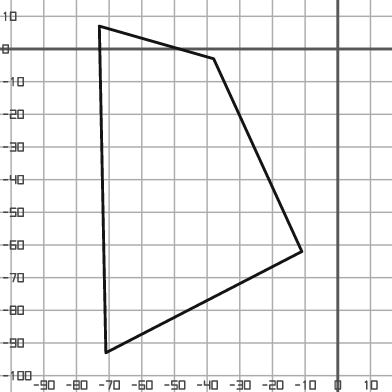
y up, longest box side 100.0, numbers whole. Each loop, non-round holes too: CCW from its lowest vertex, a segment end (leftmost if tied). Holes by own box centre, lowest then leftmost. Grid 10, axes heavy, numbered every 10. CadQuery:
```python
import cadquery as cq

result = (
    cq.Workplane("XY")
    .moveTo(-71.0, -93.0)
    .lineTo(-11.0, -62.0)
    .lineTo(-38.0, -3.0)
    .lineTo(-73.0, 7.0)
    .close()
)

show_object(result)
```